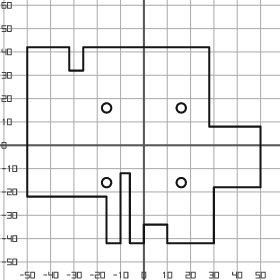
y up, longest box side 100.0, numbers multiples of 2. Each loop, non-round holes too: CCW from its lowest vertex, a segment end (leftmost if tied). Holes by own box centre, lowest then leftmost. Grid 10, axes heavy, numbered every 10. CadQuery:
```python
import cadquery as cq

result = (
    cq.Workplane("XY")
    .moveTo(-16.0, -42.0)
    .lineTo(-10.0, -42.0)
    .lineTo(-10.0, -12.0)
    .lineTo(-6.0, -12.0)
    .lineTo(-6.0, -42.0)
    .lineTo(0.0, -42.0)
    .lineTo(0.0, -34.0)
    .lineTo(10.0, -34.0)
    .lineTo(10.0, -42.0)
    .lineTo(30.0, -42.0)
    .lineTo(30.0, -18.0)
    .lineTo(50.0, -18.0)
    .lineTo(50.0, 8.0)
    .lineTo(28.0, 8.0)
    .lineTo(28.0, 42.0)
    .lineTo(-26.0, 42.0)
    .lineTo(-26.0, 32.0)
    .lineTo(-32.0, 32.0)
    .lineTo(-32.0, 42.0)
    .lineTo(-50.0, 42.0)
    .lineTo(-50.0, -22.0)
    .lineTo(-16.0, -22.0)
    .close()
    .moveTo(-16.0, -16.0)
    .circle(2.0)
    .moveTo(16.0, -16.0)
    .circle(2.0)
    .moveTo(-16.0, 16.0)
    .circle(2.0)
    .moveTo(16.0, 16.0)
    .circle(2.0)
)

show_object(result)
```